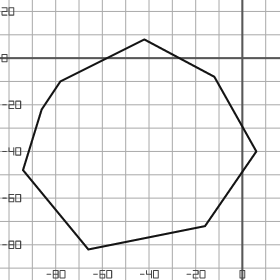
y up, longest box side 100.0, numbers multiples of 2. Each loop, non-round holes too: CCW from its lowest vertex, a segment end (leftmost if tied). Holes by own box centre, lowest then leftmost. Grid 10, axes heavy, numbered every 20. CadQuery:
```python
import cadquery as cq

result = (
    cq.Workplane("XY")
    .moveTo(-66.0, -82.0)
    .lineTo(-16.0, -72.0)
    .lineTo(6.0, -40.0)
    .lineTo(-12.0, -8.0)
    .lineTo(-42.0, 8.0)
    .lineTo(-78.0, -10.0)
    .lineTo(-86.0, -22.0)
    .lineTo(-94.0, -48.0)
    .close()
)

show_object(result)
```